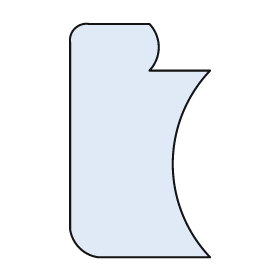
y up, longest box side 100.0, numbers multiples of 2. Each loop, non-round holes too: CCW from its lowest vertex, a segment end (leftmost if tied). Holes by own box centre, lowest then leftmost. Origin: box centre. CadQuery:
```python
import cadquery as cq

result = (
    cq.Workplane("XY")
    .moveTo(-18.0, -50.0)
    .lineTo(30.0, -50.0)
    .threePointArc((14.0, -10.0), (30.0, 30.0))
    .lineTo(4.0, 30.0)
    .threePointArc((8.0, 40.0), (4.0, 50.0))
    .lineTo(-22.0, 50.0)
    .threePointArc((-28.0, 48.0), (-30.0, 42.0))
    .lineTo(-30.0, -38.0)
    .threePointArc((-26.0, -46.0), (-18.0, -50.0))
    .close()
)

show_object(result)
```